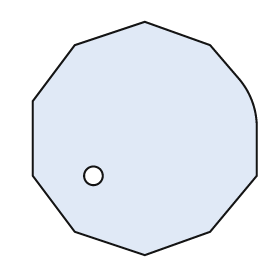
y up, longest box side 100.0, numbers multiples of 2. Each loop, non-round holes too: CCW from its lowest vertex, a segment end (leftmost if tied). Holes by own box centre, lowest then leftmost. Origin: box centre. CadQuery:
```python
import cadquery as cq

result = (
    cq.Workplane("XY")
    .moveTo(0.0, -50.0)
    .lineTo(28.0, -40.0)
    .lineTo(48.0, -16.0)
    .lineTo(48.0, 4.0)
    .threePointArc((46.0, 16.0), (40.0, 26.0))
    .lineTo(28.0, 40.0)
    .lineTo(0.0, 50.0)
    .lineTo(-30.0, 40.0)
    .lineTo(-48.0, 16.0)
    .lineTo(-48.0, -16.0)
    .lineTo(-30.0, -40.0)
    .close()
    .moveTo(-22.0, -16.0)
    .circle(4.0)
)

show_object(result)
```